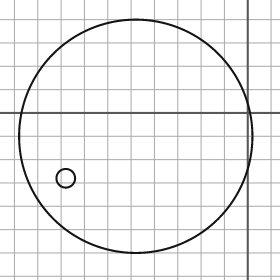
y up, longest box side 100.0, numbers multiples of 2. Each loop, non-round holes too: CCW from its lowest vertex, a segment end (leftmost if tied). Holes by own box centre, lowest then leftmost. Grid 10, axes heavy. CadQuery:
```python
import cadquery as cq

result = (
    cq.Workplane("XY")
    .moveTo(-48.0, -10.0)
    .circle(50.0)
    .moveTo(-78.0, -28.0)
    .circle(4.0)
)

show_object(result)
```